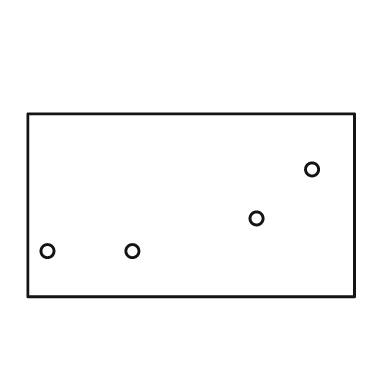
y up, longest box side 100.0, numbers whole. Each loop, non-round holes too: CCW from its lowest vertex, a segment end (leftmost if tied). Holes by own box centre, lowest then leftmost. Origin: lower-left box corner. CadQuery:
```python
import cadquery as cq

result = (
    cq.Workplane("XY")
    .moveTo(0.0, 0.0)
    .lineTo(100.0, 0.0)
    .lineTo(100.0, 56.0)
    .lineTo(0.0, 56.0)
    .close()
    .moveTo(6.0, 14.0)
    .circle(2.0)
    .moveTo(32.0, 14.0)
    .circle(2.0)
    .moveTo(70.0, 24.0)
    .circle(2.0)
    .moveTo(87.0, 39.0)
    .circle(2.0)
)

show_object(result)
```